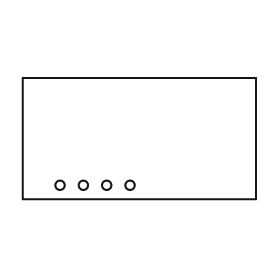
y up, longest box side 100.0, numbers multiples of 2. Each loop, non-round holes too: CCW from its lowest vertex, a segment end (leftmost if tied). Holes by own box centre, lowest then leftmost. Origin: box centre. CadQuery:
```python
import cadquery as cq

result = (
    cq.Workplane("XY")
    .moveTo(-50.0, -26.0)
    .lineTo(50.0, -26.0)
    .lineTo(50.0, 26.0)
    .lineTo(-50.0, 26.0)
    .close()
    .moveTo(-34.0, -20.0)
    .circle(2.0)
    .moveTo(-24.0, -20.0)
    .circle(2.0)
    .moveTo(-14.0, -20.0)
    .circle(2.0)
    .moveTo(-4.0, -20.0)
    .circle(2.0)
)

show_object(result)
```